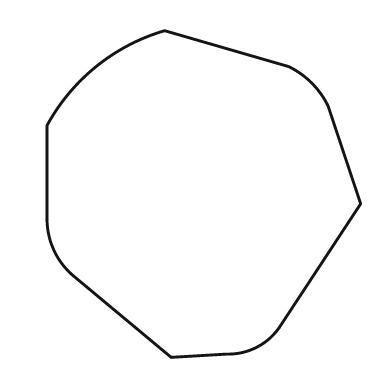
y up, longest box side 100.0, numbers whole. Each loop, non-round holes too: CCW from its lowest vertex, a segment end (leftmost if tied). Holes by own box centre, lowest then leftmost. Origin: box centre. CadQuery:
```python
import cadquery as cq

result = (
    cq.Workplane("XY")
    .moveTo(-10.0, -50.0)
    .lineTo(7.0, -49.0)
    .threePointArc((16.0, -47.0), (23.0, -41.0))
    .lineTo(48.0, -3.0)
    .lineTo(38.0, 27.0)
    .threePointArc((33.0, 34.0), (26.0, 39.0))
    .lineTo(-12.0, 50.0)
    .threePointArc((-33.0, 39.0), (-48.0, 21.0))
    .lineTo(-48.0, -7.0)
    .threePointArc((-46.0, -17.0), (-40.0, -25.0))
    .close()
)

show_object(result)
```